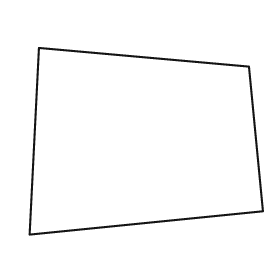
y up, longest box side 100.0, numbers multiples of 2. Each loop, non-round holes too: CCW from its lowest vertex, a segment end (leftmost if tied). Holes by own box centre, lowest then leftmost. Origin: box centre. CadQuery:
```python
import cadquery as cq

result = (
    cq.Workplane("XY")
    .moveTo(-50.0, -40.0)
    .lineTo(50.0, -30.0)
    .lineTo(44.0, 32.0)
    .lineTo(-46.0, 40.0)
    .close()
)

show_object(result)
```